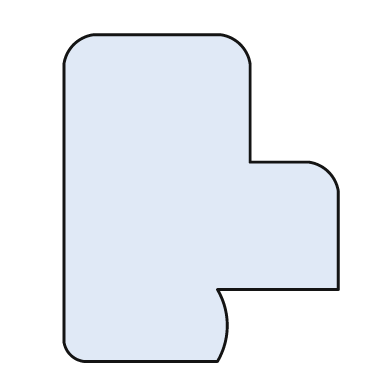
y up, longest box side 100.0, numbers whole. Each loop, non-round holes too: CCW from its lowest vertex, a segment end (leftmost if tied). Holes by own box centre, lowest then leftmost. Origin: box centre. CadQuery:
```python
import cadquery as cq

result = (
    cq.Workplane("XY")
    .moveTo(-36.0, -50.0)
    .lineTo(5.0, -50.0)
    .threePointArc((8.0, -39.0), (5.0, -28.0))
    .lineTo(42.0, -28.0)
    .lineTo(42.0, 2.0)
    .threePointArc((39.0, 8.0), (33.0, 11.0))
    .lineTo(15.0, 11.0)
    .lineTo(15.0, 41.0)
    .threePointArc((12.0, 47.0), (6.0, 50.0))
    .lineTo(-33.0, 50.0)
    .threePointArc((-39.0, 47.0), (-42.0, 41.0))
    .lineTo(-42.0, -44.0)
    .threePointArc((-40.0, -48.0), (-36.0, -50.0))
    .close()
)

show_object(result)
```